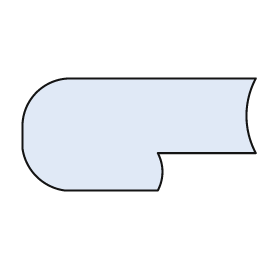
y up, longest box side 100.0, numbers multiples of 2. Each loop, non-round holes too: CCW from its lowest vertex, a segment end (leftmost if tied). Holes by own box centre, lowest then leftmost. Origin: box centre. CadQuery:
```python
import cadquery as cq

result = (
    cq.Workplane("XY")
    .moveTo(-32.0, -24.0)
    .lineTo(8.0, -24.0)
    .threePointArc((10.0, -16.0), (8.0, -8.0))
    .lineTo(50.0, -8.0)
    .threePointArc((46.0, 8.0), (50.0, 24.0))
    .lineTo(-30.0, 24.0)
    .threePointArc((-44.0, 18.0), (-50.0, 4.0))
    .lineTo(-50.0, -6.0)
    .threePointArc((-44.0, -18.0), (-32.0, -24.0))
    .close()
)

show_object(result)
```